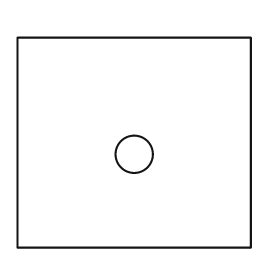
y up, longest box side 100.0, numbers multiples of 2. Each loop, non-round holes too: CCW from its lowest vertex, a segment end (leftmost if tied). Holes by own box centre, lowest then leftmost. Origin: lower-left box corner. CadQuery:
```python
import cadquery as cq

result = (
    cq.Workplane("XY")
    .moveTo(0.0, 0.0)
    .lineTo(100.0, 0.0)
    .lineTo(100.0, 90.0)
    .lineTo(0.0, 90.0)
    .close()
    .moveTo(50.0, 40.0)
    .circle(8.0)
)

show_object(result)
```